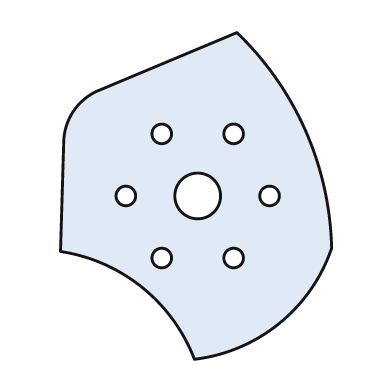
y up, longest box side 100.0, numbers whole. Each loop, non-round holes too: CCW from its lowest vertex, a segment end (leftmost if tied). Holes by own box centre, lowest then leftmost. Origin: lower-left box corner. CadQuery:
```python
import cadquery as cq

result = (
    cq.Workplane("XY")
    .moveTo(41.0, 0.0)
    .threePointArc((67.0, 11.0), (83.0, 34.0))
    .threePointArc((75.0, 70.0), (54.0, 100.0))
    .lineTo(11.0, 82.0)
    .threePointArc((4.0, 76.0), (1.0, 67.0))
    .lineTo(0.0, 33.0)
    .threePointArc((25.0, 22.0), (41.0, 0.0))
    .close()
    .moveTo(31.0, 31.0)
    .circle(3.0)
    .moveTo(53.0, 31.0)
    .circle(3.0)
    .moveTo(20.0, 50.0)
    .circle(3.0)
    .moveTo(42.0, 50.0)
    .circle(7.0)
    .moveTo(64.0, 50.0)
    .circle(3.0)
    .moveTo(31.0, 69.0)
    .circle(3.0)
    .moveTo(53.0, 69.0)
    .circle(3.0)
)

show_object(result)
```